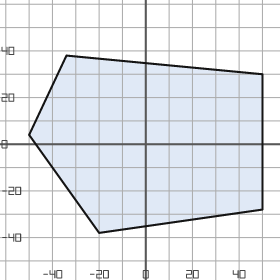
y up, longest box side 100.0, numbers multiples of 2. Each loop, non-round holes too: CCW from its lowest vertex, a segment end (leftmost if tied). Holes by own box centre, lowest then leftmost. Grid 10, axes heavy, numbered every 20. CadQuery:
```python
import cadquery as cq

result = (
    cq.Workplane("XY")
    .moveTo(-20.0, -38.0)
    .lineTo(50.0, -28.0)
    .lineTo(50.0, 30.0)
    .lineTo(-34.0, 38.0)
    .lineTo(-50.0, 4.0)
    .close()
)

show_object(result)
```